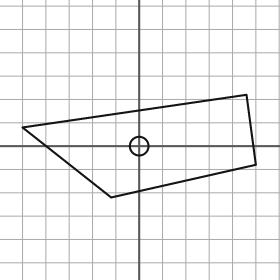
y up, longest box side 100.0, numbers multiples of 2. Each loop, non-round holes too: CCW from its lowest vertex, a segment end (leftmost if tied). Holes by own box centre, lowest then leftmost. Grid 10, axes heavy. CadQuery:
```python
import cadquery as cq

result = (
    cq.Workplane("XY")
    .moveTo(-12.0, -22.0)
    .lineTo(50.0, -8.0)
    .lineTo(46.0, 22.0)
    .lineTo(-50.0, 8.0)
    .close()
    .moveTo(0.0, 0.0)
    .circle(4.0)
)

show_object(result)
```